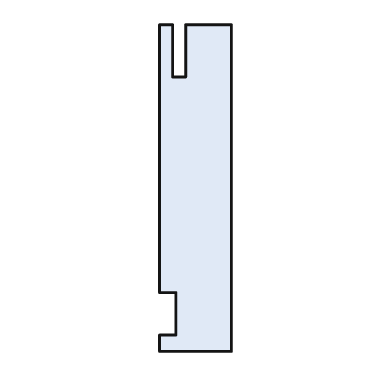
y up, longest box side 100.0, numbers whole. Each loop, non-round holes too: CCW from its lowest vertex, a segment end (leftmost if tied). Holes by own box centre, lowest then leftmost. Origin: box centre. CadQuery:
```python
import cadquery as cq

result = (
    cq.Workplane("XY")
    .moveTo(-11.0, -50.0)
    .lineTo(11.0, -50.0)
    .lineTo(11.0, 50.0)
    .lineTo(-3.0, 50.0)
    .lineTo(-3.0, 34.0)
    .lineTo(-7.0, 34.0)
    .lineTo(-7.0, 50.0)
    .lineTo(-11.0, 50.0)
    .lineTo(-11.0, -32.0)
    .lineTo(-6.0, -32.0)
    .lineTo(-6.0, -45.0)
    .lineTo(-11.0, -45.0)
    .close()
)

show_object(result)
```